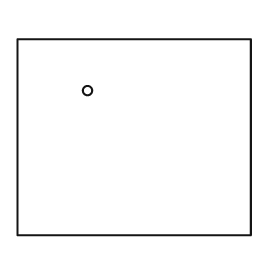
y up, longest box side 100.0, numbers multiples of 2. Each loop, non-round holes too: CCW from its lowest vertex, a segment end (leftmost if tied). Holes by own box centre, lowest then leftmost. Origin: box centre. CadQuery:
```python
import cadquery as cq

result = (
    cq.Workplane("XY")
    .moveTo(-50.0, -42.0)
    .lineTo(50.0, -42.0)
    .lineTo(50.0, 42.0)
    .lineTo(-50.0, 42.0)
    .close()
    .moveTo(-20.0, 20.0)
    .circle(2.0)
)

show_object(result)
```